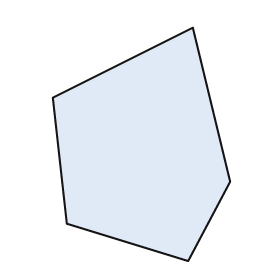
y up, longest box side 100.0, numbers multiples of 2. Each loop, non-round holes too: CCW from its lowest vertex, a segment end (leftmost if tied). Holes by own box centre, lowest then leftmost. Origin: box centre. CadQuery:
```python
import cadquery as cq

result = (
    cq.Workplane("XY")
    .moveTo(20.0, -50.0)
    .lineTo(38.0, -16.0)
    .lineTo(22.0, 50.0)
    .lineTo(-38.0, 20.0)
    .lineTo(-32.0, -34.0)
    .close()
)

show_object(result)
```